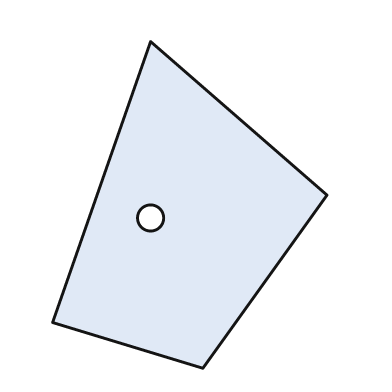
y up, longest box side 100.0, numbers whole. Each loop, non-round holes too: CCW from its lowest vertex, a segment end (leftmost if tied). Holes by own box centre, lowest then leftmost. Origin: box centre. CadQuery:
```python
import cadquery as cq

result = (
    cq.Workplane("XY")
    .moveTo(4.0, -50.0)
    .lineTo(42.0, 3.0)
    .lineTo(-12.0, 50.0)
    .lineTo(-42.0, -36.0)
    .close()
    .moveTo(-12.0, -4.0)
    .circle(4.0)
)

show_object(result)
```